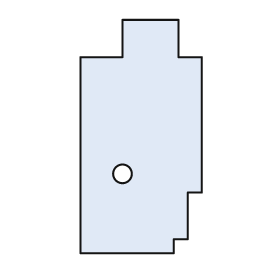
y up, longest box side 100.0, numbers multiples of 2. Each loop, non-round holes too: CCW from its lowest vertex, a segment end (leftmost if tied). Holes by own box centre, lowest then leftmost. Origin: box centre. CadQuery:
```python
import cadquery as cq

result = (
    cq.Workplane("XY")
    .moveTo(-26.0, -50.0)
    .lineTo(14.0, -50.0)
    .lineTo(14.0, -44.0)
    .lineTo(20.0, -44.0)
    .lineTo(20.0, -24.0)
    .lineTo(26.0, -24.0)
    .lineTo(26.0, 34.0)
    .lineTo(16.0, 34.0)
    .lineTo(16.0, 50.0)
    .lineTo(-8.0, 50.0)
    .lineTo(-8.0, 34.0)
    .lineTo(-26.0, 34.0)
    .close()
    .moveTo(-8.0, -16.0)
    .circle(4.0)
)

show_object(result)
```